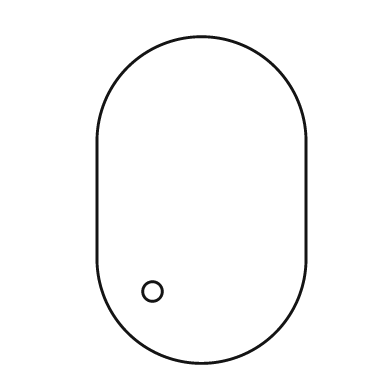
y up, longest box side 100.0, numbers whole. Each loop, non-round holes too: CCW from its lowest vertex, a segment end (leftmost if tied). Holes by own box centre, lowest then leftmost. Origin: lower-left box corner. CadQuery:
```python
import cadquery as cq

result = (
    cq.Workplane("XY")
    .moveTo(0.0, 32.0)
    .threePointArc((32.0, 0.0), (64.0, 32.0))
    .lineTo(64.0, 68.0)
    .threePointArc((32.0, 100.0), (0.0, 68.0))
    .close()
    .moveTo(17.0, 22.0)
    .circle(3.0)
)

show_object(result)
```